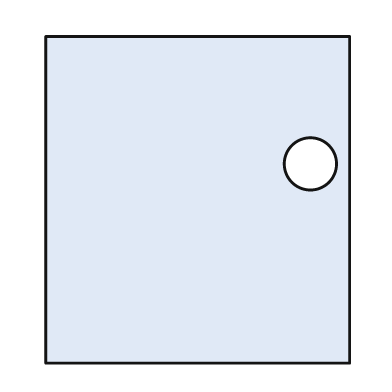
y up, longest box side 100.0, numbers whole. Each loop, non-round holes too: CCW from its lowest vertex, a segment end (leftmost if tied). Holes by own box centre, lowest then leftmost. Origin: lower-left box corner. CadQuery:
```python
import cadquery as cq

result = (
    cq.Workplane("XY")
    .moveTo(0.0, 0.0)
    .lineTo(93.0, 0.0)
    .lineTo(93.0, 100.0)
    .lineTo(0.0, 100.0)
    .close()
    .moveTo(81.0, 61.0)
    .circle(8.0)
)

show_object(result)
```